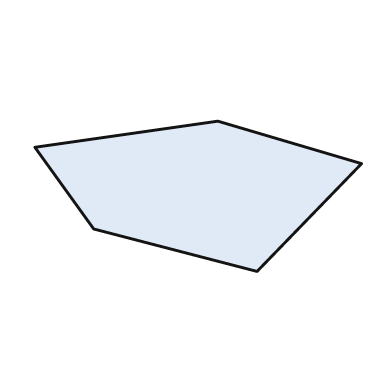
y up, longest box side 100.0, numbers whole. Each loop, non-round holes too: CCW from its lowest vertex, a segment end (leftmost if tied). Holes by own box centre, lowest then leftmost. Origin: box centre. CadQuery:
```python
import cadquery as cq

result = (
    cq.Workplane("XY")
    .moveTo(18.0, -23.0)
    .lineTo(50.0, 10.0)
    .lineTo(6.0, 23.0)
    .lineTo(-50.0, 15.0)
    .lineTo(-32.0, -10.0)
    .close()
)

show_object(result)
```